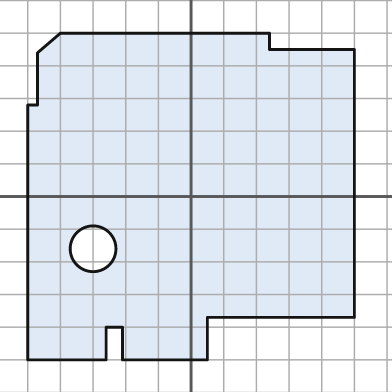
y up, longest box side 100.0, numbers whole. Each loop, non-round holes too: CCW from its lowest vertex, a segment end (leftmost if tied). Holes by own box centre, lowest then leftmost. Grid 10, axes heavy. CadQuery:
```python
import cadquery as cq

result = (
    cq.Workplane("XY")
    .moveTo(-50.0, -50.0)
    .lineTo(-26.0, -50.0)
    .lineTo(-26.0, -40.0)
    .lineTo(-21.0, -40.0)
    .lineTo(-21.0, -50.0)
    .lineTo(5.0, -50.0)
    .lineTo(5.0, -37.0)
    .lineTo(50.0, -37.0)
    .lineTo(50.0, 45.0)
    .lineTo(24.0, 45.0)
    .lineTo(24.0, 50.0)
    .lineTo(-40.0, 50.0)
    .lineTo(-47.0, 44.0)
    .lineTo(-47.0, 28.0)
    .lineTo(-50.0, 28.0)
    .close()
    .moveTo(-30.0, -16.0)
    .circle(7.0)
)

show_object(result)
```